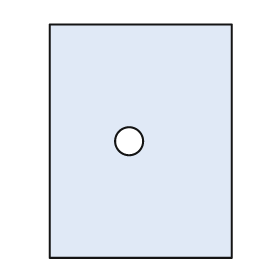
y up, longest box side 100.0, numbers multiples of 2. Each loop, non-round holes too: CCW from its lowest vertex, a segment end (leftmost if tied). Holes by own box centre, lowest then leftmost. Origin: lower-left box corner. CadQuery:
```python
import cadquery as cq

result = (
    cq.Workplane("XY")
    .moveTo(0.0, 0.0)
    .lineTo(78.0, 0.0)
    .lineTo(78.0, 100.0)
    .lineTo(0.0, 100.0)
    .close()
    .moveTo(34.0, 50.0)
    .circle(6.0)
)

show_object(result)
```